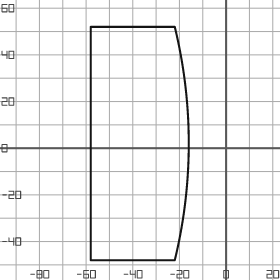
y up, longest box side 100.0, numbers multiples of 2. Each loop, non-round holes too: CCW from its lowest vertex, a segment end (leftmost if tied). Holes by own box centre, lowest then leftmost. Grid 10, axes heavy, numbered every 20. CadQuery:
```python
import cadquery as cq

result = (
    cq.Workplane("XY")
    .moveTo(-58.0, -48.0)
    .lineTo(-22.0, -48.0)
    .threePointArc((-16.0, 2.0), (-22.0, 52.0))
    .lineTo(-58.0, 52.0)
    .close()
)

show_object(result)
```